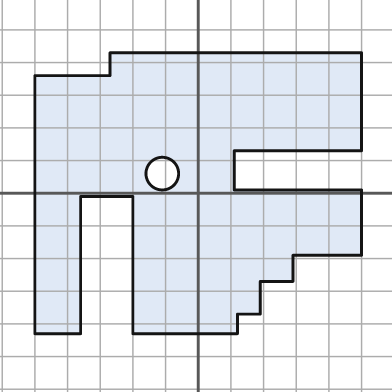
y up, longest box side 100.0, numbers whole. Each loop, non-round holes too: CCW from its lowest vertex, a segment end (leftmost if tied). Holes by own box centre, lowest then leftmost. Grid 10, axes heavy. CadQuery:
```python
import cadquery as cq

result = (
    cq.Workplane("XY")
    .moveTo(-50.0, -43.0)
    .lineTo(-36.0, -43.0)
    .lineTo(-36.0, -1.0)
    .lineTo(-20.0, -1.0)
    .lineTo(-20.0, -43.0)
    .lineTo(12.0, -43.0)
    .lineTo(12.0, -37.0)
    .lineTo(19.0, -37.0)
    .lineTo(19.0, -27.0)
    .lineTo(29.0, -27.0)
    .lineTo(29.0, -19.0)
    .lineTo(50.0, -19.0)
    .lineTo(50.0, 1.0)
    .lineTo(11.0, 1.0)
    .lineTo(11.0, 13.0)
    .lineTo(50.0, 13.0)
    .lineTo(50.0, 43.0)
    .lineTo(-27.0, 43.0)
    .lineTo(-27.0, 36.0)
    .lineTo(-50.0, 36.0)
    .close()
    .moveTo(-11.0, 6.0)
    .circle(5.0)
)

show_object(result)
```